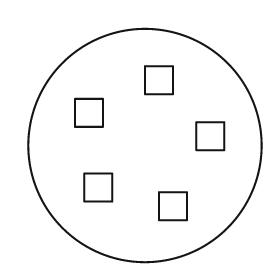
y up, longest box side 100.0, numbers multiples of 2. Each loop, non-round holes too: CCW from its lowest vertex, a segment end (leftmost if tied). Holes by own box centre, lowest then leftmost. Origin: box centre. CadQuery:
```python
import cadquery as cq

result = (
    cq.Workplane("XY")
    .moveTo(0.0, 0.0)
    .circle(50.0)
    .moveTo(6.0, -32.0)
    .lineTo(18.0, -32.0)
    .lineTo(18.0, -20.0)
    .lineTo(6.0, -20.0)
    .close()
    .moveTo(-26.0, -24.0)
    .lineTo(-14.0, -24.0)
    .lineTo(-14.0, -12.0)
    .lineTo(-26.0, -12.0)
    .close()
    .moveTo(22.0, -2.0)
    .lineTo(34.0, -2.0)
    .lineTo(34.0, 10.0)
    .lineTo(22.0, 10.0)
    .close()
    .moveTo(-30.0, 8.0)
    .lineTo(-18.0, 8.0)
    .lineTo(-18.0, 20.0)
    .lineTo(-30.0, 20.0)
    .close()
    .moveTo(0.0, 22.0)
    .lineTo(12.0, 22.0)
    .lineTo(12.0, 34.0)
    .lineTo(0.0, 34.0)
    .close()
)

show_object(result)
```